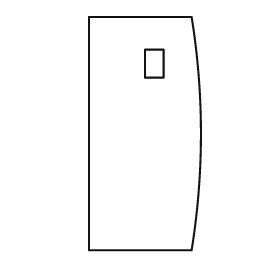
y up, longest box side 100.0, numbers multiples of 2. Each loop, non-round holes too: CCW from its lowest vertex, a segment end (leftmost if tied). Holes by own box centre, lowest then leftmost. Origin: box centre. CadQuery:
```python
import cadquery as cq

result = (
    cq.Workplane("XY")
    .moveTo(-24.0, -50.0)
    .lineTo(20.0, -50.0)
    .threePointArc((24.0, 0.0), (20.0, 50.0))
    .lineTo(-24.0, 50.0)
    .close()
    .moveTo(0.0, 24.0)
    .lineTo(8.0, 24.0)
    .lineTo(8.0, 36.0)
    .lineTo(0.0, 36.0)
    .close()
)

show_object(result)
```